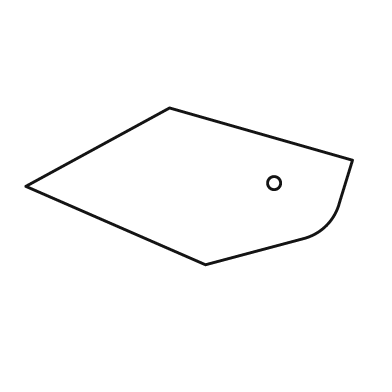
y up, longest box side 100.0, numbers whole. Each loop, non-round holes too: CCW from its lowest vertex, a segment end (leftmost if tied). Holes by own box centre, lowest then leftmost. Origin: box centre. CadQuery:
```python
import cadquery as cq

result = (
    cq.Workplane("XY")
    .moveTo(5.0, -24.0)
    .lineTo(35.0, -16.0)
    .threePointArc((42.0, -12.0), (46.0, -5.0))
    .lineTo(50.0, 8.0)
    .lineTo(-6.0, 24.0)
    .lineTo(-50.0, 0.0)
    .close()
    .moveTo(26.0, 1.0)
    .circle(2.0)
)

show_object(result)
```